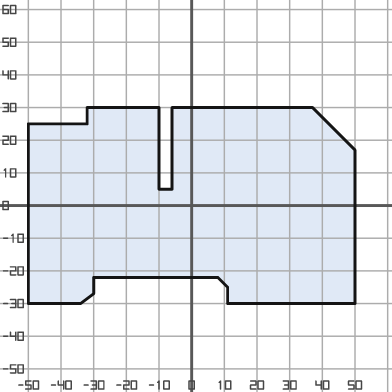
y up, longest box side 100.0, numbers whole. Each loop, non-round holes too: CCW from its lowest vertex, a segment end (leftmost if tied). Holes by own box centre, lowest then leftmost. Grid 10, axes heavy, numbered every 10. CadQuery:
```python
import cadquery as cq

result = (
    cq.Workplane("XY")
    .moveTo(-50.0, -30.0)
    .lineTo(-34.0, -30.0)
    .lineTo(-30.0, -27.0)
    .lineTo(-30.0, -22.0)
    .lineTo(8.0, -22.0)
    .lineTo(11.0, -25.0)
    .lineTo(11.0, -30.0)
    .lineTo(50.0, -30.0)
    .lineTo(50.0, 17.0)
    .lineTo(37.0, 30.0)
    .lineTo(-6.0, 30.0)
    .lineTo(-6.0, 5.0)
    .lineTo(-10.0, 5.0)
    .lineTo(-10.0, 30.0)
    .lineTo(-32.0, 30.0)
    .lineTo(-32.0, 25.0)
    .lineTo(-50.0, 25.0)
    .close()
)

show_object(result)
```